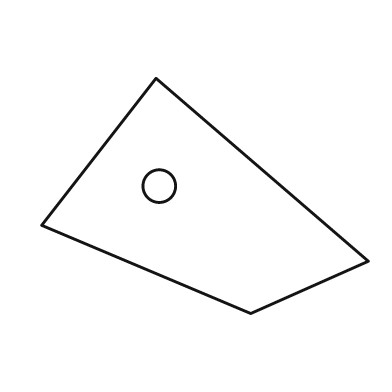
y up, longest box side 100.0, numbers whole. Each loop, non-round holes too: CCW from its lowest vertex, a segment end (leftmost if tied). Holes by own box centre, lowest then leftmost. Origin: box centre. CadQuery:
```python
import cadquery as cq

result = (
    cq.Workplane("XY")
    .moveTo(14.0, -36.0)
    .lineTo(50.0, -20.0)
    .lineTo(-15.0, 36.0)
    .lineTo(-50.0, -9.0)
    .close()
    .moveTo(-14.0, 3.0)
    .circle(5.0)
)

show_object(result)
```